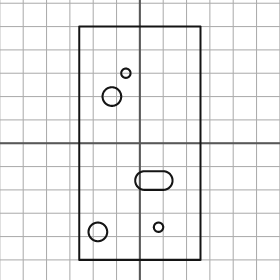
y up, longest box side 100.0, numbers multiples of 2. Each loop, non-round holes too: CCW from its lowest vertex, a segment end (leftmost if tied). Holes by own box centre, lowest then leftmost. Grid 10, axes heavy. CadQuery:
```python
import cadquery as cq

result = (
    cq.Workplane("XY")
    .moveTo(-26.0, -50.0)
    .lineTo(26.0, -50.0)
    .lineTo(26.0, 50.0)
    .lineTo(-26.0, 50.0)
    .close()
    .moveTo(-18.0, -38.0)
    .circle(4.0)
    .moveTo(8.0, -36.0)
    .circle(2.0)
    .moveTo(2.0, -20.0)
    .lineTo(10.0, -20.0)
    .threePointArc((14.0, -16.0), (10.0, -12.0))
    .lineTo(2.0, -12.0)
    .threePointArc((-2.0, -16.0), (2.0, -20.0))
    .close()
    .moveTo(-12.0, 20.0)
    .circle(4.0)
    .moveTo(-6.0, 30.0)
    .circle(2.0)
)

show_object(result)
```